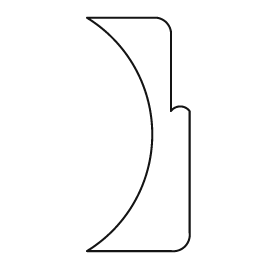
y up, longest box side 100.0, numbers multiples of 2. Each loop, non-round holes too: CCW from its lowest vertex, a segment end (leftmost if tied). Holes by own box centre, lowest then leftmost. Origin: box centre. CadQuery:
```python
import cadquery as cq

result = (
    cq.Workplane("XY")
    .moveTo(-22.0, -50.0)
    .lineTo(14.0, -50.0)
    .threePointArc((20.0, -48.0), (22.0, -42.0))
    .lineTo(22.0, 10.0)
    .threePointArc((18.0, 12.0), (14.0, 10.0))
    .lineTo(14.0, 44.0)
    .threePointArc((12.0, 48.0), (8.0, 50.0))
    .lineTo(-22.0, 50.0)
    .threePointArc((6.0, 0.0), (-22.0, -50.0))
    .close()
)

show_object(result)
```